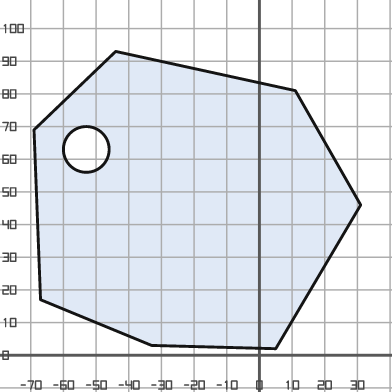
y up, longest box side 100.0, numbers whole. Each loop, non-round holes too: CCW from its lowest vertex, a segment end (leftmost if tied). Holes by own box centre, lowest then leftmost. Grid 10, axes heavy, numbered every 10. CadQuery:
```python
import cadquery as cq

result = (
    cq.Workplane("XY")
    .moveTo(5.0, 2.0)
    .lineTo(31.0, 46.0)
    .lineTo(11.0, 81.0)
    .lineTo(-44.0, 93.0)
    .lineTo(-69.0, 69.0)
    .lineTo(-67.0, 17.0)
    .lineTo(-33.0, 3.0)
    .close()
    .moveTo(-53.0, 63.0)
    .circle(7.0)
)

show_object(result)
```